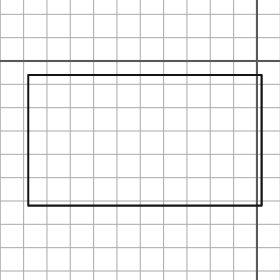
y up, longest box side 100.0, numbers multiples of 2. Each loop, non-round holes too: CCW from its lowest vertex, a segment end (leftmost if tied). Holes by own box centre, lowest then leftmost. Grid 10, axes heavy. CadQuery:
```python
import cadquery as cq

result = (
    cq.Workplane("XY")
    .moveTo(-98.0, -62.0)
    .lineTo(2.0, -62.0)
    .lineTo(2.0, -6.0)
    .lineTo(-98.0, -6.0)
    .close()
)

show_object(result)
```